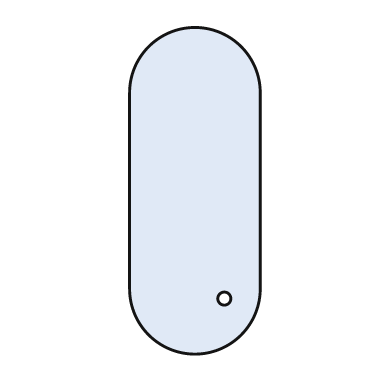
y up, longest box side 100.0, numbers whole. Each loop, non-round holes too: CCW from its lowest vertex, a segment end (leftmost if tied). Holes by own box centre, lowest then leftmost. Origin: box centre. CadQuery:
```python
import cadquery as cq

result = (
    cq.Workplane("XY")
    .moveTo(-20.0, -30.0)
    .threePointArc((0.0, -50.0), (20.0, -30.0))
    .lineTo(20.0, 30.0)
    .threePointArc((0.0, 50.0), (-20.0, 30.0))
    .close()
    .moveTo(9.0, -33.0)
    .circle(2.0)
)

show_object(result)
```